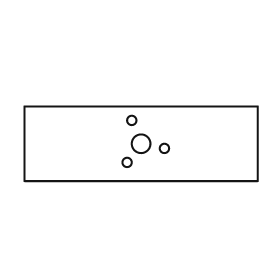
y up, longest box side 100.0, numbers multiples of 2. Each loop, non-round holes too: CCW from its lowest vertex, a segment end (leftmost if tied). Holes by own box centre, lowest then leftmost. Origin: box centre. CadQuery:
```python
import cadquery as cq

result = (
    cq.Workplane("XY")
    .moveTo(-50.0, -16.0)
    .lineTo(50.0, -16.0)
    .lineTo(50.0, 16.0)
    .lineTo(-50.0, 16.0)
    .close()
    .moveTo(-6.0, -8.0)
    .circle(2.0)
    .moveTo(10.0, -2.0)
    .circle(2.0)
    .moveTo(0.0, 0.0)
    .circle(4.0)
    .moveTo(-4.0, 10.0)
    .circle(2.0)
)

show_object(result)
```